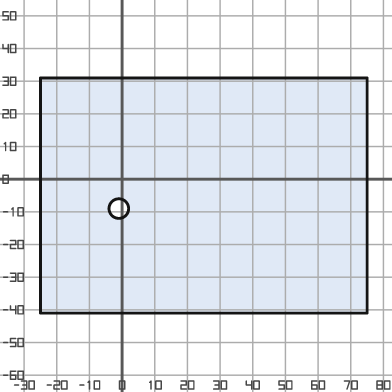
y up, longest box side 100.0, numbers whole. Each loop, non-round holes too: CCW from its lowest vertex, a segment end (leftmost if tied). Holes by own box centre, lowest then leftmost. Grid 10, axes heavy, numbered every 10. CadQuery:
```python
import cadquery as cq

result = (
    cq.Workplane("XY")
    .moveTo(-25.0, -41.0)
    .lineTo(75.0, -41.0)
    .lineTo(75.0, 31.0)
    .lineTo(-25.0, 31.0)
    .close()
    .moveTo(-1.0, -9.0)
    .circle(3.0)
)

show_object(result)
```